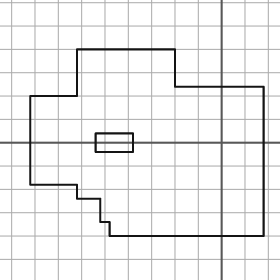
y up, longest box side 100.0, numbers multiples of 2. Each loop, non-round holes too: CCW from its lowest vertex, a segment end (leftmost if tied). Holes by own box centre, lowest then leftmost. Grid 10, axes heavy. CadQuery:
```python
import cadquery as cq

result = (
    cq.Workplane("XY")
    .moveTo(-48.0, -40.0)
    .lineTo(18.0, -40.0)
    .lineTo(18.0, 24.0)
    .lineTo(-20.0, 24.0)
    .lineTo(-20.0, 40.0)
    .lineTo(-62.0, 40.0)
    .lineTo(-62.0, 20.0)
    .lineTo(-82.0, 20.0)
    .lineTo(-82.0, -18.0)
    .lineTo(-62.0, -18.0)
    .lineTo(-62.0, -24.0)
    .lineTo(-52.0, -24.0)
    .lineTo(-52.0, -34.0)
    .lineTo(-48.0, -34.0)
    .close()
    .moveTo(-54.0, -4.0)
    .lineTo(-38.0, -4.0)
    .lineTo(-38.0, 4.0)
    .lineTo(-54.0, 4.0)
    .close()
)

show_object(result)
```